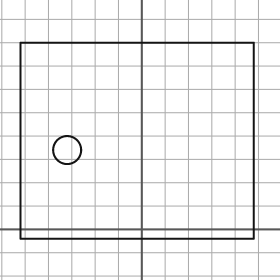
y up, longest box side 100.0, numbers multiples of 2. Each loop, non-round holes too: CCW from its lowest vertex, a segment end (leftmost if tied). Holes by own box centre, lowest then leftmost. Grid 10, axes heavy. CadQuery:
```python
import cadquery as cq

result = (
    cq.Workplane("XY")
    .moveTo(-52.0, -4.0)
    .lineTo(48.0, -4.0)
    .lineTo(48.0, 80.0)
    .lineTo(-52.0, 80.0)
    .close()
    .moveTo(-32.0, 34.0)
    .circle(6.0)
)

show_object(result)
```